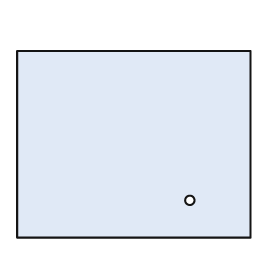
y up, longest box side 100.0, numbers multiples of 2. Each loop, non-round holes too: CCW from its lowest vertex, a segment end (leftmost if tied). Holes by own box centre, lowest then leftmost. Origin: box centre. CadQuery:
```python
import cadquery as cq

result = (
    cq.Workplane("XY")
    .moveTo(-50.0, -40.0)
    .lineTo(50.0, -40.0)
    .lineTo(50.0, 40.0)
    .lineTo(-50.0, 40.0)
    .close()
    .moveTo(24.0, -24.0)
    .circle(2.0)
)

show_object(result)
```